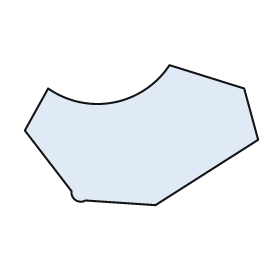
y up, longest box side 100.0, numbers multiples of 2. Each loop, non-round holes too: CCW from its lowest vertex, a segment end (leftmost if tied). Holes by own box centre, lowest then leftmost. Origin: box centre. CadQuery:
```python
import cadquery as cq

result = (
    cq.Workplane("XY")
    .moveTo(6.0, -30.0)
    .lineTo(50.0, -2.0)
    .lineTo(44.0, 20.0)
    .lineTo(12.0, 30.0)
    .threePointArc((-12.0, 14.0), (-40.0, 20.0))
    .lineTo(-50.0, 2.0)
    .lineTo(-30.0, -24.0)
    .threePointArc((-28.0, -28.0), (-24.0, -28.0))
    .close()
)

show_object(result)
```